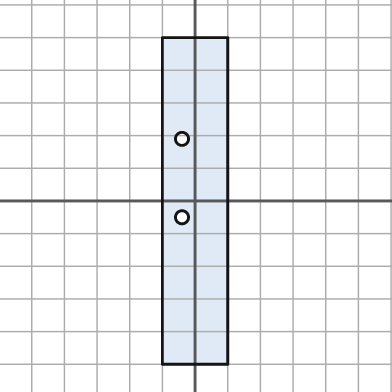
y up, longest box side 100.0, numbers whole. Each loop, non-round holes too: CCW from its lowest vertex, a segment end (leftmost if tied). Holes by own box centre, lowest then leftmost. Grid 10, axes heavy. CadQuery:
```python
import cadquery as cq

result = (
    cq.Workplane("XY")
    .moveTo(-10.0, -50.0)
    .lineTo(10.0, -50.0)
    .lineTo(10.0, 50.0)
    .lineTo(-10.0, 50.0)
    .close()
    .moveTo(-4.0, -5.0)
    .circle(2.0)
    .moveTo(-4.0, 19.0)
    .circle(2.0)
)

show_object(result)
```